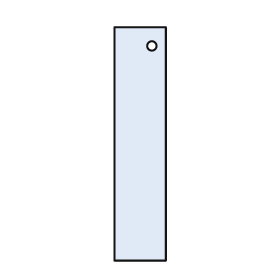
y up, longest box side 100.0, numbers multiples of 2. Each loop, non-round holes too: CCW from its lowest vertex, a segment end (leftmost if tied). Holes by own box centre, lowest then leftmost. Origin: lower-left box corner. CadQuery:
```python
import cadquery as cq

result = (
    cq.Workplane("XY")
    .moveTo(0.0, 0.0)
    .lineTo(22.0, 0.0)
    .lineTo(22.0, 100.0)
    .lineTo(0.0, 100.0)
    .close()
    .moveTo(16.0, 92.0)
    .circle(2.0)
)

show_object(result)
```